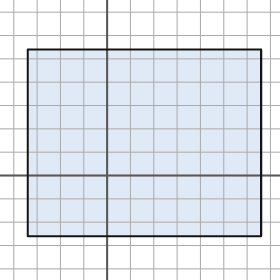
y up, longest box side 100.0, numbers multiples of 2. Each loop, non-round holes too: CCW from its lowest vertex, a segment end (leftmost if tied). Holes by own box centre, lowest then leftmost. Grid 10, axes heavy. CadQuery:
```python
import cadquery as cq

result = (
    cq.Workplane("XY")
    .moveTo(-34.0, -26.0)
    .lineTo(66.0, -26.0)
    .lineTo(66.0, 54.0)
    .lineTo(-34.0, 54.0)
    .close()
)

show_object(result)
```